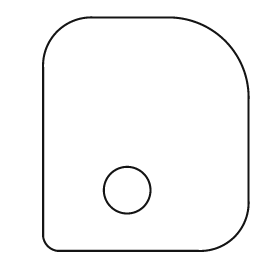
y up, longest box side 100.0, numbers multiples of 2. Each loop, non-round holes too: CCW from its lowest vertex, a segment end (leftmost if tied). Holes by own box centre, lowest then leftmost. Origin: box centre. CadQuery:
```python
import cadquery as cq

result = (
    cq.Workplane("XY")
    .moveTo(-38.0, -50.0)
    .lineTo(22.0, -50.0)
    .threePointArc((38.0, -44.0), (44.0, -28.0))
    .lineTo(44.0, 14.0)
    .threePointArc((34.0, 40.0), (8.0, 50.0))
    .lineTo(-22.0, 50.0)
    .threePointArc((-38.0, 44.0), (-44.0, 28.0))
    .lineTo(-44.0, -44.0)
    .threePointArc((-42.0, -48.0), (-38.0, -50.0))
    .close()
    .moveTo(-8.0, -24.0)
    .circle(10.0)
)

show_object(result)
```